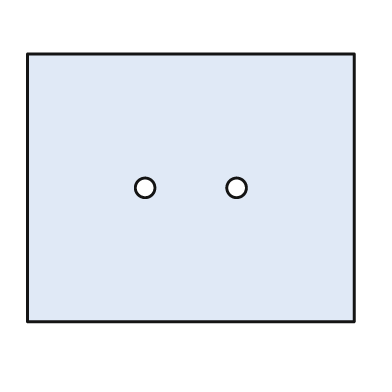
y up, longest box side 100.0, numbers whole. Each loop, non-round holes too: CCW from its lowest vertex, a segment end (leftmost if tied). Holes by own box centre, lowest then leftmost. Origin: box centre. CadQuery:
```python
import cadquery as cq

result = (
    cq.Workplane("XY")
    .moveTo(-50.0, -41.0)
    .lineTo(50.0, -41.0)
    .lineTo(50.0, 41.0)
    .lineTo(-50.0, 41.0)
    .close()
    .moveTo(-14.0, 0.0)
    .circle(3.0)
    .moveTo(14.0, 0.0)
    .circle(3.0)
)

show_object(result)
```